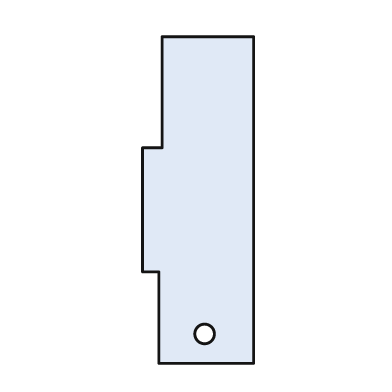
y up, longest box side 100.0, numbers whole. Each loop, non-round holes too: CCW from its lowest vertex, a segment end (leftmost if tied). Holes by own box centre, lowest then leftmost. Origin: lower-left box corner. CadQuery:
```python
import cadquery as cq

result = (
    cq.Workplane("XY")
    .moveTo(5.0, 0.0)
    .lineTo(34.0, 0.0)
    .lineTo(34.0, 100.0)
    .lineTo(6.0, 100.0)
    .lineTo(6.0, 66.0)
    .lineTo(0.0, 66.0)
    .lineTo(0.0, 28.0)
    .lineTo(5.0, 28.0)
    .close()
    .moveTo(19.0, 9.0)
    .circle(3.0)
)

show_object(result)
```